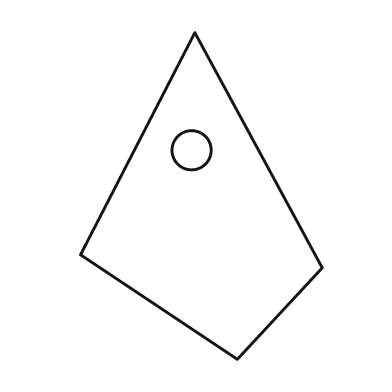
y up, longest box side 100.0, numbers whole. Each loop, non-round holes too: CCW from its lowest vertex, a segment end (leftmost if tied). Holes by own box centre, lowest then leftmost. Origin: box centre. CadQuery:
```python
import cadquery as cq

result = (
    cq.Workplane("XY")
    .moveTo(11.0, -50.0)
    .lineTo(37.0, -22.0)
    .lineTo(-2.0, 50.0)
    .lineTo(-37.0, -18.0)
    .close()
    .moveTo(-3.0, 14.0)
    .circle(6.0)
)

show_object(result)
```